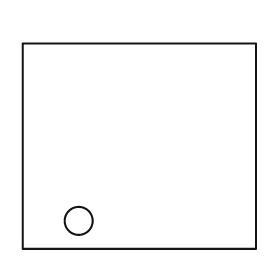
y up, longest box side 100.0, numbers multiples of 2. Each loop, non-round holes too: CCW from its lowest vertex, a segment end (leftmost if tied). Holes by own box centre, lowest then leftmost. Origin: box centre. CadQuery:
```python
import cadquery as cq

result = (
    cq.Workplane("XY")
    .moveTo(-50.0, -44.0)
    .lineTo(50.0, -44.0)
    .lineTo(50.0, 44.0)
    .lineTo(-50.0, 44.0)
    .close()
    .moveTo(-26.0, -32.0)
    .circle(6.0)
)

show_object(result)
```